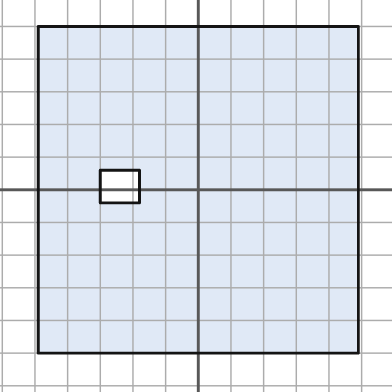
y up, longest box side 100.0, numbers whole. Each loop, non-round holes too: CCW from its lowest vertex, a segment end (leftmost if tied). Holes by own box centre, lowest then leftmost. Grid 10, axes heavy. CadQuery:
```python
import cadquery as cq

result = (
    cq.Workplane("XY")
    .moveTo(-49.0, -50.0)
    .lineTo(49.0, -50.0)
    .lineTo(49.0, 50.0)
    .lineTo(-49.0, 50.0)
    .close()
    .moveTo(-30.0, -4.0)
    .lineTo(-18.0, -4.0)
    .lineTo(-18.0, 6.0)
    .lineTo(-30.0, 6.0)
    .close()
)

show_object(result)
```